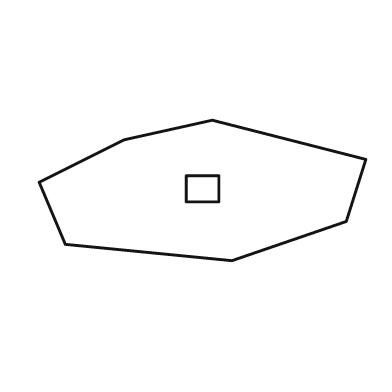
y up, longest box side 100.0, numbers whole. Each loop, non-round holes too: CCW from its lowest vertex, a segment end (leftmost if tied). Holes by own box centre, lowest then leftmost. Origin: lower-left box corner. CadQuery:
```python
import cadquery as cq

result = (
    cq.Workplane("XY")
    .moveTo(59.0, 0.0)
    .lineTo(94.0, 12.0)
    .lineTo(100.0, 31.0)
    .lineTo(53.0, 43.0)
    .lineTo(26.0, 37.0)
    .lineTo(0.0, 24.0)
    .lineTo(8.0, 5.0)
    .close()
    .moveTo(45.0, 18.0)
    .lineTo(55.0, 18.0)
    .lineTo(55.0, 26.0)
    .lineTo(45.0, 26.0)
    .close()
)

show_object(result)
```